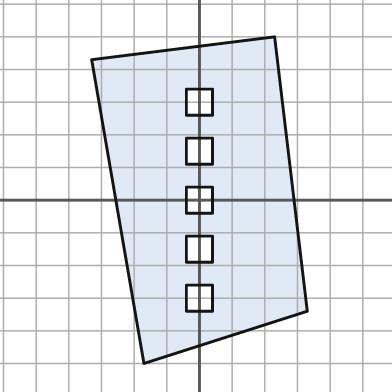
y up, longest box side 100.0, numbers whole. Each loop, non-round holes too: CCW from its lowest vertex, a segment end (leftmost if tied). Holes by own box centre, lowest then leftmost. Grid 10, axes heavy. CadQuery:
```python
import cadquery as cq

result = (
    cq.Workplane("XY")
    .moveTo(-17.0, -50.0)
    .lineTo(33.0, -34.0)
    .lineTo(23.0, 50.0)
    .lineTo(-33.0, 43.0)
    .close()
    .moveTo(-4.0, -34.0)
    .lineTo(4.0, -34.0)
    .lineTo(4.0, -26.0)
    .lineTo(-4.0, -26.0)
    .close()
    .moveTo(-4.0, -19.0)
    .lineTo(4.0, -19.0)
    .lineTo(4.0, -11.0)
    .lineTo(-4.0, -11.0)
    .close()
    .moveTo(-4.0, -4.0)
    .lineTo(4.0, -4.0)
    .lineTo(4.0, 4.0)
    .lineTo(-4.0, 4.0)
    .close()
    .moveTo(-4.0, 11.0)
    .lineTo(4.0, 11.0)
    .lineTo(4.0, 19.0)
    .lineTo(-4.0, 19.0)
    .close()
    .moveTo(-4.0, 26.0)
    .lineTo(4.0, 26.0)
    .lineTo(4.0, 34.0)
    .lineTo(-4.0, 34.0)
    .close()
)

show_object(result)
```